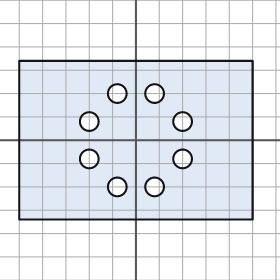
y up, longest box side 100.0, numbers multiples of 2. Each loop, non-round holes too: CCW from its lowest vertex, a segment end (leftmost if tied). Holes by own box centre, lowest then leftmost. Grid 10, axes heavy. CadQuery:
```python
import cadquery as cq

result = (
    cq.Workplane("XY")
    .moveTo(-50.0, -34.0)
    .lineTo(50.0, -34.0)
    .lineTo(50.0, 34.0)
    .lineTo(-50.0, 34.0)
    .close()
    .moveTo(-8.0, -20.0)
    .circle(4.0)
    .moveTo(8.0, -20.0)
    .circle(4.0)
    .moveTo(-20.0, -8.0)
    .circle(4.0)
    .moveTo(20.0, -8.0)
    .circle(4.0)
    .moveTo(-20.0, 8.0)
    .circle(4.0)
    .moveTo(20.0, 8.0)
    .circle(4.0)
    .moveTo(-8.0, 20.0)
    .circle(4.0)
    .moveTo(8.0, 20.0)
    .circle(4.0)
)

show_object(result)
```